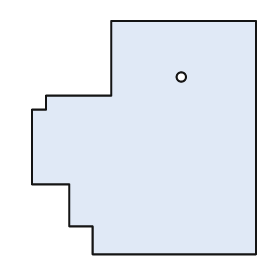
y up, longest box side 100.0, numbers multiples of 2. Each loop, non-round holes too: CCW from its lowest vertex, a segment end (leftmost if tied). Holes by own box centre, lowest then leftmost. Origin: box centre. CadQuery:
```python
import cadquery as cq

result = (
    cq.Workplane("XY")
    .moveTo(-22.0, -50.0)
    .lineTo(48.0, -50.0)
    .lineTo(48.0, 50.0)
    .lineTo(-14.0, 50.0)
    .lineTo(-14.0, 18.0)
    .lineTo(-42.0, 18.0)
    .lineTo(-42.0, 12.0)
    .lineTo(-48.0, 12.0)
    .lineTo(-48.0, -20.0)
    .lineTo(-32.0, -20.0)
    .lineTo(-32.0, -38.0)
    .lineTo(-22.0, -38.0)
    .close()
    .moveTo(16.0, 26.0)
    .circle(2.0)
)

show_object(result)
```